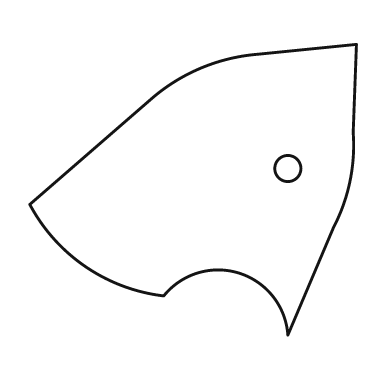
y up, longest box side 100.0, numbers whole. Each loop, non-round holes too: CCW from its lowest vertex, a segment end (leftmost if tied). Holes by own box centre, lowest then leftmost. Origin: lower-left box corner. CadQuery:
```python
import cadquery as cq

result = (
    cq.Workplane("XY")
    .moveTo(79.0, 0.0)
    .lineTo(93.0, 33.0)
    .threePointArc((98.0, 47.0), (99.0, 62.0))
    .lineTo(100.0, 89.0)
    .lineTo(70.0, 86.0)
    .threePointArc((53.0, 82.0), (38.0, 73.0))
    .lineTo(0.0, 40.0)
    .threePointArc((17.0, 21.0), (41.0, 12.0))
    .threePointArc((64.0, 19.0), (79.0, 0.0))
    .close()
    .moveTo(79.0, 51.0)
    .circle(4.0)
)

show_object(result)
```